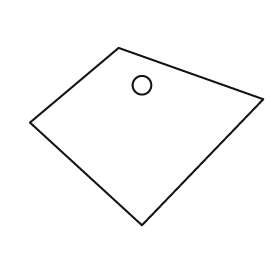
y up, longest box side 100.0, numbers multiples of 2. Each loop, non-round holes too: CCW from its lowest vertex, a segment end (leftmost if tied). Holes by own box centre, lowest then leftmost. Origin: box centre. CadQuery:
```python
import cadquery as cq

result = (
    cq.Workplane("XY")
    .moveTo(-2.0, -38.0)
    .lineTo(50.0, 16.0)
    .lineTo(-12.0, 38.0)
    .lineTo(-50.0, 6.0)
    .close()
    .moveTo(-2.0, 22.0)
    .circle(4.0)
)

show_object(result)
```